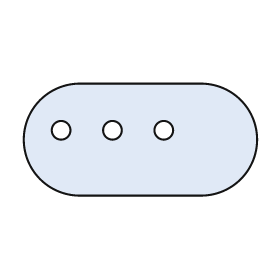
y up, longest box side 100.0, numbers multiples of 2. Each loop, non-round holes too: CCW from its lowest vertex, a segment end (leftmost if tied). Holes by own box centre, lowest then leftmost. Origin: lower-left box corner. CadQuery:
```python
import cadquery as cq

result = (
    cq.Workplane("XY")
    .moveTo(24.0, 0.0)
    .lineTo(76.0, 0.0)
    .threePointArc((100.0, 24.0), (76.0, 48.0))
    .lineTo(24.0, 48.0)
    .threePointArc((0.0, 24.0), (24.0, 0.0))
    .close()
    .moveTo(16.0, 28.0)
    .circle(4.0)
    .moveTo(38.0, 28.0)
    .circle(4.0)
    .moveTo(60.0, 28.0)
    .circle(4.0)
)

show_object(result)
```